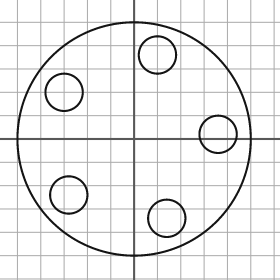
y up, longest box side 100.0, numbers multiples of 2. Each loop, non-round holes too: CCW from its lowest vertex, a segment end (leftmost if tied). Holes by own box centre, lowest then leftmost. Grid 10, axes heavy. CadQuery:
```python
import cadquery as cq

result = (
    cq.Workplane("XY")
    .moveTo(0.0, 0.0)
    .circle(50.0)
    .moveTo(14.0, -34.0)
    .circle(8.0)
    .moveTo(-28.0, -24.0)
    .circle(8.0)
    .moveTo(36.0, 2.0)
    .circle(8.0)
    .moveTo(-30.0, 20.0)
    .circle(8.0)
    .moveTo(10.0, 36.0)
    .circle(8.0)
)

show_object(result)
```